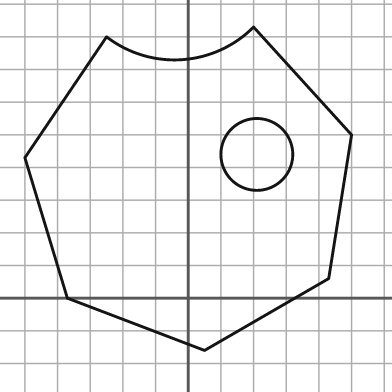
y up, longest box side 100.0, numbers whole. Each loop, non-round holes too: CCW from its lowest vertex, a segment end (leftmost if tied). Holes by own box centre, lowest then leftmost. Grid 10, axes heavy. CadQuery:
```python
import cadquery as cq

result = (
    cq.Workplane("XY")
    .moveTo(5.0, -16.0)
    .lineTo(43.0, 6.0)
    .lineTo(50.0, 50.0)
    .lineTo(20.0, 83.0)
    .threePointArc((-2.0, 73.0), (-25.0, 80.0))
    .lineTo(-50.0, 43.0)
    .lineTo(-37.0, 0.0)
    .close()
    .moveTo(21.0, 44.0)
    .circle(11.0)
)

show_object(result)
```